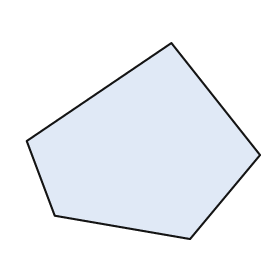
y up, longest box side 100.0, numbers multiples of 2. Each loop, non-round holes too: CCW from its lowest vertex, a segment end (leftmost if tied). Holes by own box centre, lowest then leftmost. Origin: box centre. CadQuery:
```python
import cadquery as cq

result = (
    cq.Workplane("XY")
    .moveTo(20.0, -42.0)
    .lineTo(50.0, -6.0)
    .lineTo(12.0, 42.0)
    .lineTo(-50.0, 0.0)
    .lineTo(-38.0, -32.0)
    .close()
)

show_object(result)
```